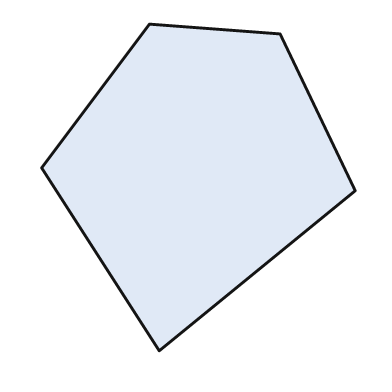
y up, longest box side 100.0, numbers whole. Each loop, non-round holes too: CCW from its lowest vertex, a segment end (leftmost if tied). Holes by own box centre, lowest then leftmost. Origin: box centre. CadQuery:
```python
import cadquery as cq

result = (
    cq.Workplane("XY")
    .moveTo(-12.0, -50.0)
    .lineTo(48.0, -1.0)
    .lineTo(25.0, 47.0)
    .lineTo(-15.0, 50.0)
    .lineTo(-48.0, 6.0)
    .close()
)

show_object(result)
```